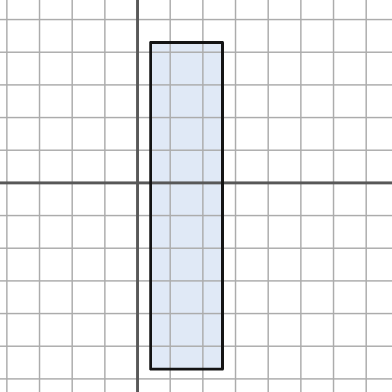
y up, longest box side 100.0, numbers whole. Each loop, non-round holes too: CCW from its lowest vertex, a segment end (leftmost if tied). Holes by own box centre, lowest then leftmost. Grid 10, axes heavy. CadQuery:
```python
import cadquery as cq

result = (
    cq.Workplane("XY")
    .moveTo(4.0, -57.0)
    .lineTo(26.0, -57.0)
    .lineTo(26.0, 43.0)
    .lineTo(4.0, 43.0)
    .close()
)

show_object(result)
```